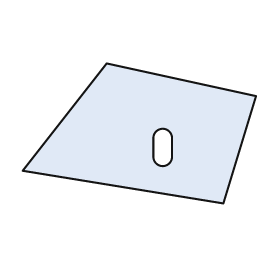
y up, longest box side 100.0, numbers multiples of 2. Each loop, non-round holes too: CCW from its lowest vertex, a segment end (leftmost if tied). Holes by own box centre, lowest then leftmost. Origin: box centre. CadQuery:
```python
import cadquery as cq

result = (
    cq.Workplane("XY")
    .moveTo(36.0, -30.0)
    .lineTo(50.0, 16.0)
    .lineTo(-14.0, 30.0)
    .lineTo(-50.0, -16.0)
    .close()
    .moveTo(6.0, -10.0)
    .threePointArc((10.0, -14.0), (14.0, -10.0))
    .lineTo(14.0, -2.0)
    .threePointArc((10.0, 2.0), (6.0, -2.0))
    .close()
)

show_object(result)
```